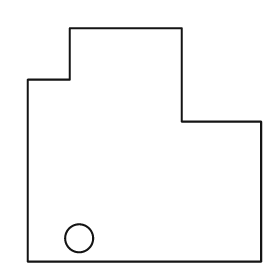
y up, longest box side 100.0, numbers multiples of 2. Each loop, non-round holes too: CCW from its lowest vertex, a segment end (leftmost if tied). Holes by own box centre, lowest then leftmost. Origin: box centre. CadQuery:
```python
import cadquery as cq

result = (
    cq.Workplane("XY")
    .moveTo(-50.0, -50.0)
    .lineTo(50.0, -50.0)
    .lineTo(50.0, 10.0)
    .lineTo(16.0, 10.0)
    .lineTo(16.0, 50.0)
    .lineTo(-32.0, 50.0)
    .lineTo(-32.0, 28.0)
    .lineTo(-50.0, 28.0)
    .close()
    .moveTo(-28.0, -40.0)
    .circle(6.0)
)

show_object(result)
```